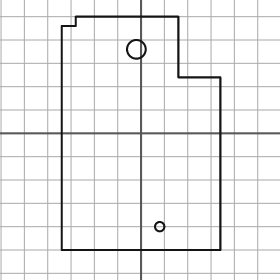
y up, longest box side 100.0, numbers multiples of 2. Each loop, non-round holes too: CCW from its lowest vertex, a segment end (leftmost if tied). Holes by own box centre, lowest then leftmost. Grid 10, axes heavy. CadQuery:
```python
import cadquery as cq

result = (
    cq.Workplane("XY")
    .moveTo(-34.0, -50.0)
    .lineTo(34.0, -50.0)
    .lineTo(34.0, 24.0)
    .lineTo(16.0, 24.0)
    .lineTo(16.0, 50.0)
    .lineTo(-28.0, 50.0)
    .lineTo(-28.0, 46.0)
    .lineTo(-34.0, 46.0)
    .close()
    .moveTo(8.0, -40.0)
    .circle(2.0)
    .moveTo(-2.0, 36.0)
    .circle(4.0)
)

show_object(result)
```